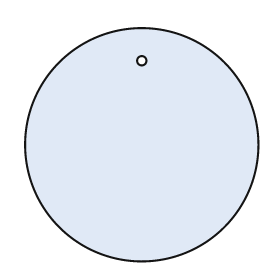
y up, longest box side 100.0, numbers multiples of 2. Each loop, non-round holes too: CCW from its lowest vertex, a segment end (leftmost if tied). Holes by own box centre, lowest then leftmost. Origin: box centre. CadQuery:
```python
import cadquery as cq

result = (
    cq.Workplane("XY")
    .moveTo(0.0, 0.0)
    .circle(50.0)
    .moveTo(0.0, 36.0)
    .circle(2.0)
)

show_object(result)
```